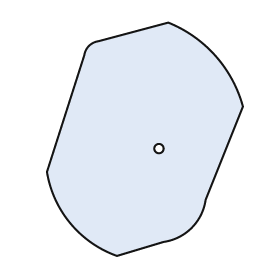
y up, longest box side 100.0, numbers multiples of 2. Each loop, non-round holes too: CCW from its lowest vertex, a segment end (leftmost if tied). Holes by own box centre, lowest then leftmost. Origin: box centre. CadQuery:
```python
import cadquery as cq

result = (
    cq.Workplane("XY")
    .moveTo(-12.0, -50.0)
    .lineTo(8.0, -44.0)
    .threePointArc((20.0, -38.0), (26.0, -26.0))
    .lineTo(42.0, 14.0)
    .threePointArc((30.0, 36.0), (10.0, 50.0))
    .lineTo(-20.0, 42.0)
    .threePointArc((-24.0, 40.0), (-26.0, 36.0))
    .lineTo(-42.0, -14.0)
    .threePointArc((-32.0, -36.0), (-12.0, -50.0))
    .close()
    .moveTo(6.0, -4.0)
    .circle(2.0)
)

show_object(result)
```